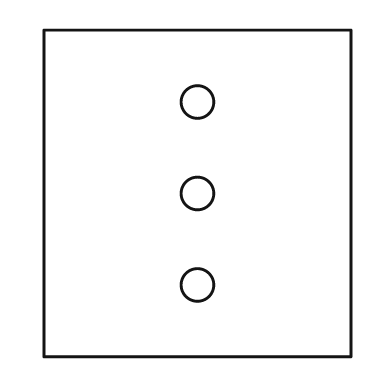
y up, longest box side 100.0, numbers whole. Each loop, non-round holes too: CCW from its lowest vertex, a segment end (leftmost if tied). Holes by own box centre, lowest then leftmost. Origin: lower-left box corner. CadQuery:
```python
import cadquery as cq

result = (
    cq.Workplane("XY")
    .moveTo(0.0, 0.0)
    .lineTo(94.0, 0.0)
    .lineTo(94.0, 100.0)
    .lineTo(0.0, 100.0)
    .close()
    .moveTo(47.0, 22.0)
    .circle(5.0)
    .moveTo(47.0, 50.0)
    .circle(5.0)
    .moveTo(47.0, 78.0)
    .circle(5.0)
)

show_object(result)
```